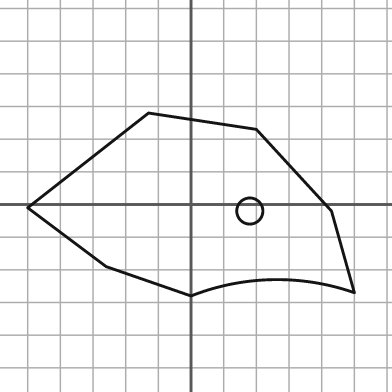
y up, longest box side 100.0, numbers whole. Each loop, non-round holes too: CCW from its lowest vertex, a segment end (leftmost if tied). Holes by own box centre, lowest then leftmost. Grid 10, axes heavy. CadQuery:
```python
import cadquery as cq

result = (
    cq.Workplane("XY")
    .moveTo(0.0, -28.0)
    .threePointArc((25.0, -23.0), (50.0, -27.0))
    .lineTo(43.0, -2.0)
    .lineTo(20.0, 23.0)
    .lineTo(-13.0, 28.0)
    .lineTo(-50.0, -1.0)
    .lineTo(-26.0, -19.0)
    .close()
    .moveTo(18.0, -2.0)
    .circle(4.0)
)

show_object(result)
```